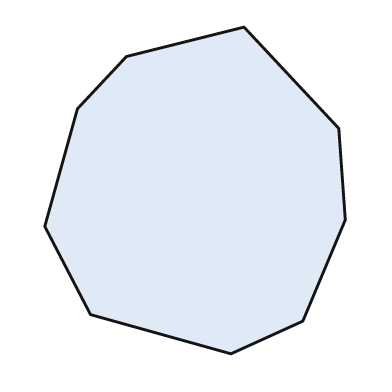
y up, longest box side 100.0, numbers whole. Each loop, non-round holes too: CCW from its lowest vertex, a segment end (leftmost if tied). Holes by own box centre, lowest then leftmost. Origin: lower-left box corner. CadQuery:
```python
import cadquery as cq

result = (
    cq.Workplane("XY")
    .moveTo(57.0, 0.0)
    .lineTo(79.0, 10.0)
    .lineTo(92.0, 41.0)
    .lineTo(90.0, 69.0)
    .lineTo(61.0, 100.0)
    .lineTo(25.0, 91.0)
    .lineTo(10.0, 75.0)
    .lineTo(0.0, 39.0)
    .lineTo(14.0, 12.0)
    .close()
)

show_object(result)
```